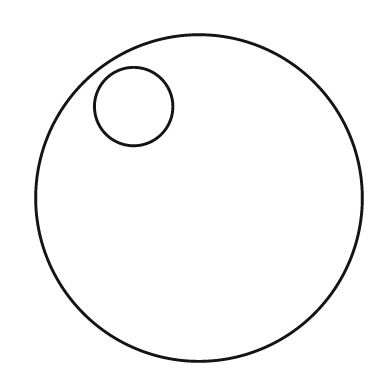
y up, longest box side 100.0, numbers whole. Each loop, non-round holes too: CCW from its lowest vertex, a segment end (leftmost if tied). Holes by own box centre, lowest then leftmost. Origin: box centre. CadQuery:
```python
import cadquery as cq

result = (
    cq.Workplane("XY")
    .moveTo(0.0, 0.0)
    .circle(50.0)
    .moveTo(-20.0, 28.0)
    .circle(12.0)
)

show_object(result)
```